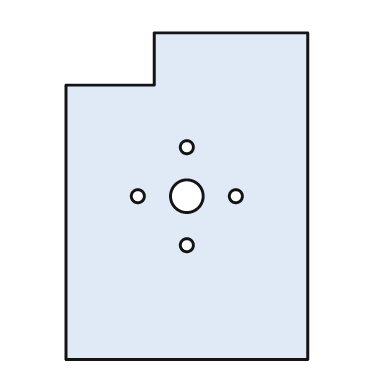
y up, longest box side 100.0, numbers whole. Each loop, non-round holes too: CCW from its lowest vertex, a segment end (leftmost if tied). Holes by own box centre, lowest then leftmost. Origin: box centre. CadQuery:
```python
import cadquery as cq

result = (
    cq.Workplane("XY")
    .moveTo(-37.0, -50.0)
    .lineTo(37.0, -50.0)
    .lineTo(37.0, 50.0)
    .lineTo(-10.0, 50.0)
    .lineTo(-10.0, 34.0)
    .lineTo(-37.0, 34.0)
    .close()
    .moveTo(0.0, -15.0)
    .circle(2.0)
    .moveTo(-15.0, 0.0)
    .circle(2.0)
    .moveTo(0.0, 0.0)
    .circle(5.0)
    .moveTo(15.0, 0.0)
    .circle(2.0)
    .moveTo(0.0, 15.0)
    .circle(2.0)
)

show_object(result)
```